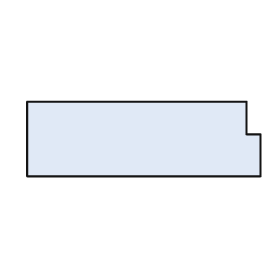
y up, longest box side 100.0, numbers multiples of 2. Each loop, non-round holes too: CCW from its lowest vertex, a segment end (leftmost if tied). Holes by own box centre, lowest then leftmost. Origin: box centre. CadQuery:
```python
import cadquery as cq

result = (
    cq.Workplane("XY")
    .moveTo(-50.0, -16.0)
    .lineTo(50.0, -16.0)
    .lineTo(50.0, 2.0)
    .lineTo(44.0, 2.0)
    .lineTo(44.0, 16.0)
    .lineTo(-50.0, 16.0)
    .close()
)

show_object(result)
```